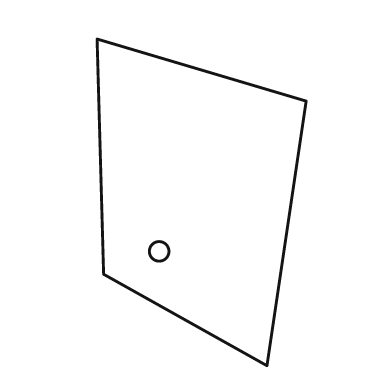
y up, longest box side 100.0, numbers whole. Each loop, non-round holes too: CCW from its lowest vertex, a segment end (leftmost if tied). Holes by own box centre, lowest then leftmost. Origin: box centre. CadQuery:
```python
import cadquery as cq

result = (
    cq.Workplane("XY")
    .moveTo(20.0, -50.0)
    .lineTo(32.0, 31.0)
    .lineTo(-32.0, 50.0)
    .lineTo(-30.0, -22.0)
    .close()
    .moveTo(-13.0, -15.0)
    .circle(3.0)
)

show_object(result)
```